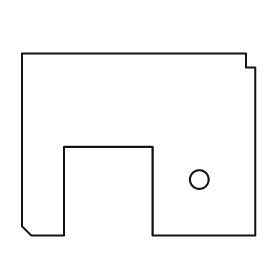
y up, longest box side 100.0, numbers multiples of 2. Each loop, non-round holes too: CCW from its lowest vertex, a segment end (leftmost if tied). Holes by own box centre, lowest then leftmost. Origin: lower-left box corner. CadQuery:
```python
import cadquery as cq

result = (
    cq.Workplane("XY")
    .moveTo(4.0, 0.0)
    .lineTo(18.0, 0.0)
    .lineTo(18.0, 38.0)
    .lineTo(56.0, 38.0)
    .lineTo(56.0, 0.0)
    .lineTo(100.0, 0.0)
    .lineTo(100.0, 72.0)
    .lineTo(96.0, 72.0)
    .lineTo(96.0, 78.0)
    .lineTo(0.0, 78.0)
    .lineTo(0.0, 4.0)
    .close()
    .moveTo(76.0, 24.0)
    .circle(4.0)
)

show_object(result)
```